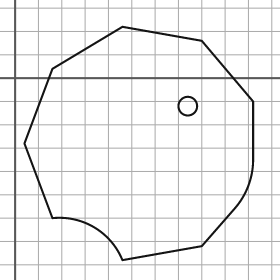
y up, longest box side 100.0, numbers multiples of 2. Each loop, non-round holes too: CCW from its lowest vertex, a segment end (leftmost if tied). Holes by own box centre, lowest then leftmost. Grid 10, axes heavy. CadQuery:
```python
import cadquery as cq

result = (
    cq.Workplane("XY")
    .moveTo(46.0, -78.0)
    .lineTo(80.0, -72.0)
    .lineTo(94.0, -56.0)
    .threePointArc((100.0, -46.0), (102.0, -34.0))
    .lineTo(102.0, -10.0)
    .lineTo(80.0, 16.0)
    .lineTo(46.0, 22.0)
    .lineTo(16.0, 4.0)
    .lineTo(4.0, -28.0)
    .lineTo(16.0, -60.0)
    .threePointArc((34.0, -64.0), (46.0, -78.0))
    .close()
    .moveTo(74.0, -12.0)
    .circle(4.0)
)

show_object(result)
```